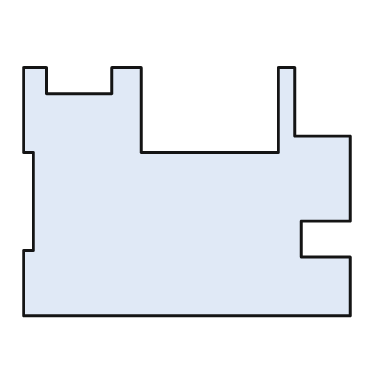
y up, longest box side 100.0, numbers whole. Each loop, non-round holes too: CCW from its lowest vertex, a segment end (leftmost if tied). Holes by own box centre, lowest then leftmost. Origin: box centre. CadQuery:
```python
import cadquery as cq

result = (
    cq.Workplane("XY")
    .moveTo(-50.0, -38.0)
    .lineTo(50.0, -38.0)
    .lineTo(50.0, -20.0)
    .lineTo(35.0, -20.0)
    .lineTo(35.0, -9.0)
    .lineTo(50.0, -9.0)
    .lineTo(50.0, 17.0)
    .lineTo(33.0, 17.0)
    .lineTo(33.0, 38.0)
    .lineTo(28.0, 38.0)
    .lineTo(28.0, 12.0)
    .lineTo(-14.0, 12.0)
    .lineTo(-14.0, 38.0)
    .lineTo(-23.0, 38.0)
    .lineTo(-23.0, 30.0)
    .lineTo(-43.0, 30.0)
    .lineTo(-43.0, 38.0)
    .lineTo(-50.0, 38.0)
    .lineTo(-50.0, 12.0)
    .lineTo(-47.0, 12.0)
    .lineTo(-47.0, -18.0)
    .lineTo(-50.0, -18.0)
    .close()
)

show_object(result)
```